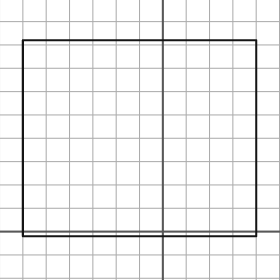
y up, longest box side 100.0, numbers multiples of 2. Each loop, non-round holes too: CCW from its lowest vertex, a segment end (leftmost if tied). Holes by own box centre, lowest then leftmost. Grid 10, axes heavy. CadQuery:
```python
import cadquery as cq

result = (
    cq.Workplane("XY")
    .moveTo(-60.0, -2.0)
    .lineTo(40.0, -2.0)
    .lineTo(40.0, 82.0)
    .lineTo(-60.0, 82.0)
    .close()
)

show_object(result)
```